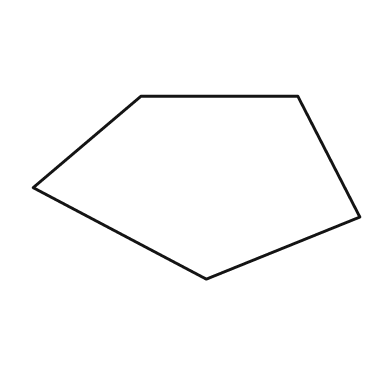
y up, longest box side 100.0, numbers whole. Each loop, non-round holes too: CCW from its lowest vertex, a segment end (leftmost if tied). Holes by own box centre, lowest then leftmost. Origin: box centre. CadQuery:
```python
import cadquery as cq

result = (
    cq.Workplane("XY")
    .moveTo(3.0, -28.0)
    .lineTo(50.0, -9.0)
    .lineTo(31.0, 28.0)
    .lineTo(-17.0, 28.0)
    .lineTo(-50.0, 0.0)
    .close()
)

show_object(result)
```